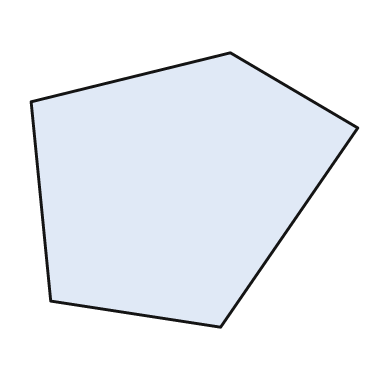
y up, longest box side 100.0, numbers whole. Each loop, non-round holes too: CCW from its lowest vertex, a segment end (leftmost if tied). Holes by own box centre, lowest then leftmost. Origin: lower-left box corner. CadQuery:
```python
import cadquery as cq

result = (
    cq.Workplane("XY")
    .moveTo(58.0, 0.0)
    .lineTo(100.0, 61.0)
    .lineTo(61.0, 84.0)
    .lineTo(0.0, 69.0)
    .lineTo(6.0, 8.0)
    .close()
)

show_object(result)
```